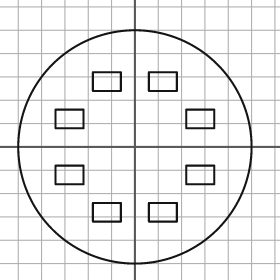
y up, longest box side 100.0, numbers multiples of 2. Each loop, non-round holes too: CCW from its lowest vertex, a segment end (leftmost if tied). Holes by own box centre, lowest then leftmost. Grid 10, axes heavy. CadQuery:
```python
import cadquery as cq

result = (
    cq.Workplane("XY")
    .moveTo(0.0, 0.0)
    .circle(50.0)
    .moveTo(-18.0, -32.0)
    .lineTo(-6.0, -32.0)
    .lineTo(-6.0, -24.0)
    .lineTo(-18.0, -24.0)
    .close()
    .moveTo(6.0, -32.0)
    .lineTo(18.0, -32.0)
    .lineTo(18.0, -24.0)
    .lineTo(6.0, -24.0)
    .close()
    .moveTo(-34.0, -16.0)
    .lineTo(-22.0, -16.0)
    .lineTo(-22.0, -8.0)
    .lineTo(-34.0, -8.0)
    .close()
    .moveTo(22.0, -16.0)
    .lineTo(34.0, -16.0)
    .lineTo(34.0, -8.0)
    .lineTo(22.0, -8.0)
    .close()
    .moveTo(-34.0, 8.0)
    .lineTo(-22.0, 8.0)
    .lineTo(-22.0, 16.0)
    .lineTo(-34.0, 16.0)
    .close()
    .moveTo(22.0, 8.0)
    .lineTo(34.0, 8.0)
    .lineTo(34.0, 16.0)
    .lineTo(22.0, 16.0)
    .close()
    .moveTo(-18.0, 24.0)
    .lineTo(-6.0, 24.0)
    .lineTo(-6.0, 32.0)
    .lineTo(-18.0, 32.0)
    .close()
    .moveTo(6.0, 24.0)
    .lineTo(18.0, 24.0)
    .lineTo(18.0, 32.0)
    .lineTo(6.0, 32.0)
    .close()
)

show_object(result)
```